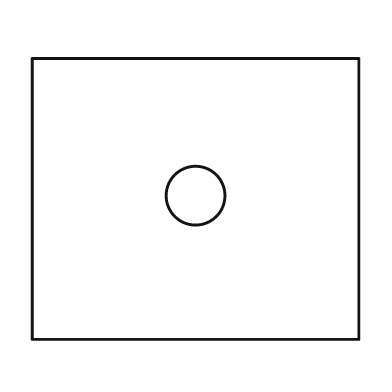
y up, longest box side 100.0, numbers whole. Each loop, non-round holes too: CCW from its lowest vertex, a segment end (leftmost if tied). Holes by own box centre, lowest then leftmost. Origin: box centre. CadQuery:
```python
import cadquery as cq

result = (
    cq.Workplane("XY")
    .moveTo(-50.0, -43.0)
    .lineTo(50.0, -43.0)
    .lineTo(50.0, 43.0)
    .lineTo(-50.0, 43.0)
    .close()
    .moveTo(0.0, 1.0)
    .circle(9.0)
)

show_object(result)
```